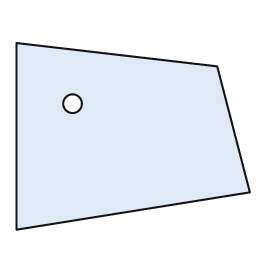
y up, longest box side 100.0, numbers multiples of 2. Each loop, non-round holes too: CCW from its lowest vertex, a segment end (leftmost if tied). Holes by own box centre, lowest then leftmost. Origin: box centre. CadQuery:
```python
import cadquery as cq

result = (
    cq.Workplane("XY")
    .moveTo(-50.0, -40.0)
    .lineTo(50.0, -24.0)
    .lineTo(36.0, 30.0)
    .lineTo(-50.0, 40.0)
    .close()
    .moveTo(-26.0, 14.0)
    .circle(4.0)
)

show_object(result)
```